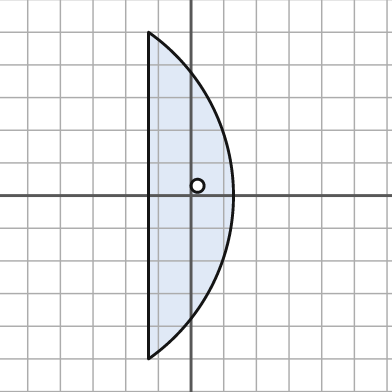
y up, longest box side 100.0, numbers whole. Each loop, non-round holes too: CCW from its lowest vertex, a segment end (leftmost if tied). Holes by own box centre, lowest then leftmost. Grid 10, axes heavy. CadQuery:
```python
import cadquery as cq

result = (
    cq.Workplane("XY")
    .moveTo(-13.0, -50.0)
    .threePointArc((13.0, 0.0), (-13.0, 50.0))
    .close()
    .moveTo(2.0, 3.0)
    .circle(2.0)
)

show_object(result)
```